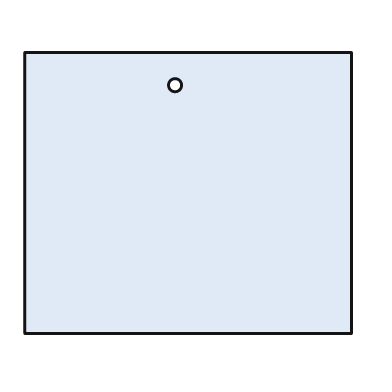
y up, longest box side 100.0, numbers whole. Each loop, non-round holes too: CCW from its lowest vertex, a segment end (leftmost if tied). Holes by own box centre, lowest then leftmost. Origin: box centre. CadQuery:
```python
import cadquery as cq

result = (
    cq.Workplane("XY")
    .moveTo(-50.0, -43.0)
    .lineTo(50.0, -43.0)
    .lineTo(50.0, 43.0)
    .lineTo(-50.0, 43.0)
    .close()
    .moveTo(-4.0, 33.0)
    .circle(2.0)
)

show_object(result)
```